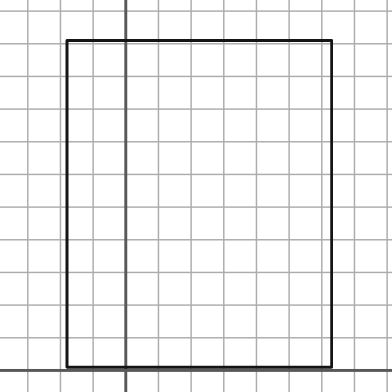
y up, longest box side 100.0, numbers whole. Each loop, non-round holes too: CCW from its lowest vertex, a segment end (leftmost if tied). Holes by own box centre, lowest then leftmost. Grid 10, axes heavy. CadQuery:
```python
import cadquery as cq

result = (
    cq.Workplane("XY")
    .moveTo(-18.0, 1.0)
    .lineTo(63.0, 1.0)
    .lineTo(63.0, 101.0)
    .lineTo(-18.0, 101.0)
    .close()
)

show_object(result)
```